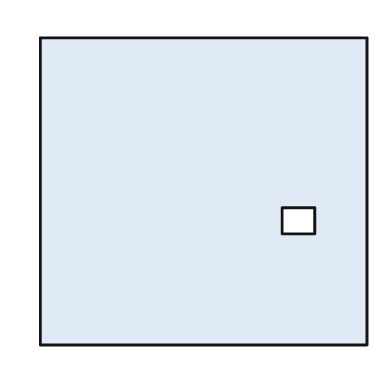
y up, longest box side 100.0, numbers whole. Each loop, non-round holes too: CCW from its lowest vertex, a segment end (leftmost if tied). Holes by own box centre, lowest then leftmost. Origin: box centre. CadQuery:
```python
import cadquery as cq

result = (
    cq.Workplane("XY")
    .moveTo(-50.0, -47.0)
    .lineTo(50.0, -47.0)
    .lineTo(50.0, 47.0)
    .lineTo(-50.0, 47.0)
    .close()
    .moveTo(24.0, -13.0)
    .lineTo(34.0, -13.0)
    .lineTo(34.0, -5.0)
    .lineTo(24.0, -5.0)
    .close()
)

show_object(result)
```